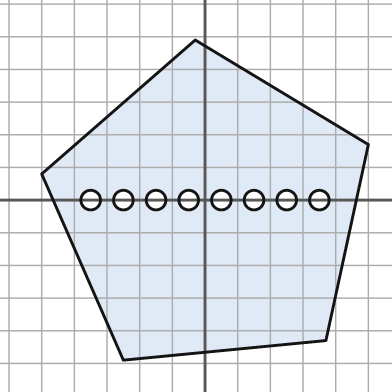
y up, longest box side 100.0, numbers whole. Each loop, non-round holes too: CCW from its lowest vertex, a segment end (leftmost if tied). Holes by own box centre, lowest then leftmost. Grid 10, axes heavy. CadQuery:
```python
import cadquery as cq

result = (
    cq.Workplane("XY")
    .moveTo(-25.0, -49.0)
    .lineTo(37.0, -43.0)
    .lineTo(50.0, 17.0)
    .lineTo(-3.0, 49.0)
    .lineTo(-50.0, 8.0)
    .close()
    .moveTo(-35.0, 0.0)
    .circle(3.0)
    .moveTo(-25.0, 0.0)
    .circle(3.0)
    .moveTo(-15.0, 0.0)
    .circle(3.0)
    .moveTo(-5.0, 0.0)
    .circle(3.0)
    .moveTo(5.0, 0.0)
    .circle(3.0)
    .moveTo(15.0, 0.0)
    .circle(3.0)
    .moveTo(25.0, 0.0)
    .circle(3.0)
    .moveTo(35.0, 0.0)
    .circle(3.0)
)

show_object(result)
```